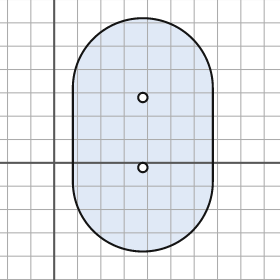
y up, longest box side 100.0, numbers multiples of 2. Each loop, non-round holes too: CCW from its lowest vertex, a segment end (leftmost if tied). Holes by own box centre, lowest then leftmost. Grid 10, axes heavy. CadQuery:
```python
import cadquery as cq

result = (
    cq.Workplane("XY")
    .moveTo(8.0, -8.0)
    .threePointArc((38.0, -38.0), (68.0, -8.0))
    .lineTo(68.0, 32.0)
    .threePointArc((38.0, 62.0), (8.0, 32.0))
    .close()
    .moveTo(38.0, -2.0)
    .circle(2.0)
    .moveTo(38.0, 28.0)
    .circle(2.0)
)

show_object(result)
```